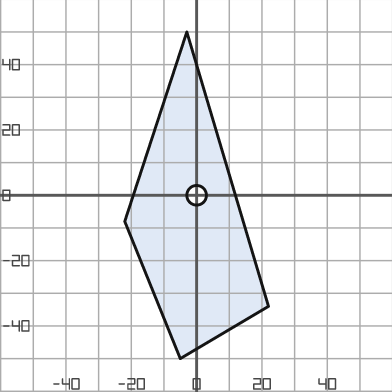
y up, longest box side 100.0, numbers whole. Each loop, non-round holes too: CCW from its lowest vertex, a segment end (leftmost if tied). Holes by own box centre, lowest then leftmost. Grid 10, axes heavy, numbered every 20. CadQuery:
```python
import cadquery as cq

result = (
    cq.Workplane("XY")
    .moveTo(-5.0, -50.0)
    .lineTo(22.0, -34.0)
    .lineTo(-3.0, 50.0)
    .lineTo(-22.0, -8.0)
    .close()
    .moveTo(0.0, 0.0)
    .circle(3.0)
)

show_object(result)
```